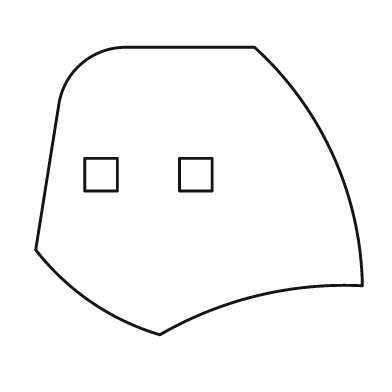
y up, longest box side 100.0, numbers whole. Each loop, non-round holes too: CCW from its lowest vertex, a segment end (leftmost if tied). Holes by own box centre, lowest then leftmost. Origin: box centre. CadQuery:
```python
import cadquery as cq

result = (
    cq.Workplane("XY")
    .moveTo(-12.0, -44.0)
    .threePointArc((18.0, -32.0), (50.0, -29.0))
    .threePointArc((41.0, 11.0), (17.0, 44.0))
    .lineTo(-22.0, 44.0)
    .threePointArc((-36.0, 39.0), (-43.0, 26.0))
    .lineTo(-50.0, -18.0)
    .threePointArc((-33.0, -34.0), (-12.0, -44.0))
    .close()
    .moveTo(-35.0, 0.0)
    .lineTo(-25.0, 0.0)
    .lineTo(-25.0, 10.0)
    .lineTo(-35.0, 10.0)
    .close()
    .moveTo(-6.0, 0.0)
    .lineTo(4.0, 0.0)
    .lineTo(4.0, 10.0)
    .lineTo(-6.0, 10.0)
    .close()
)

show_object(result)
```